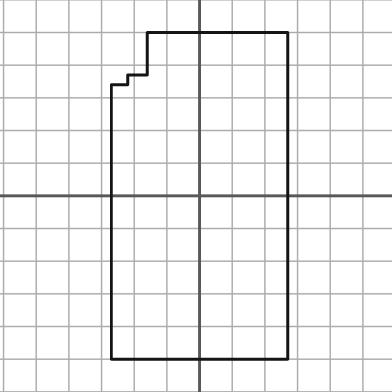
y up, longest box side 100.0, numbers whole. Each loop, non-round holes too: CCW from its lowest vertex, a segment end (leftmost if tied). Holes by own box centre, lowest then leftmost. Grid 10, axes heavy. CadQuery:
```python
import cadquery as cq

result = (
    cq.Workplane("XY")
    .moveTo(-27.0, -50.0)
    .lineTo(27.0, -50.0)
    .lineTo(27.0, 50.0)
    .lineTo(-16.0, 50.0)
    .lineTo(-16.0, 37.0)
    .lineTo(-22.0, 37.0)
    .lineTo(-22.0, 34.0)
    .lineTo(-27.0, 34.0)
    .close()
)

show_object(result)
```